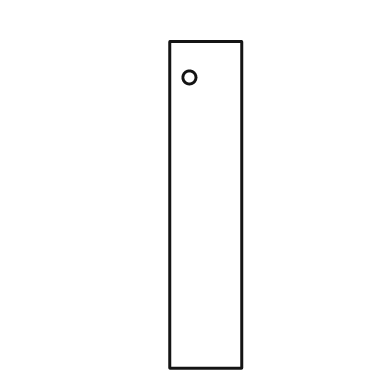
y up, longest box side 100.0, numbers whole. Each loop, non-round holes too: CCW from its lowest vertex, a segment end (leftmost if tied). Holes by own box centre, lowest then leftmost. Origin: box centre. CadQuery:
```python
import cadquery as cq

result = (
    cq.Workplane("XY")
    .moveTo(-11.0, -50.0)
    .lineTo(11.0, -50.0)
    .lineTo(11.0, 50.0)
    .lineTo(-11.0, 50.0)
    .close()
    .moveTo(-5.0, 39.0)
    .circle(2.0)
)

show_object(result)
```